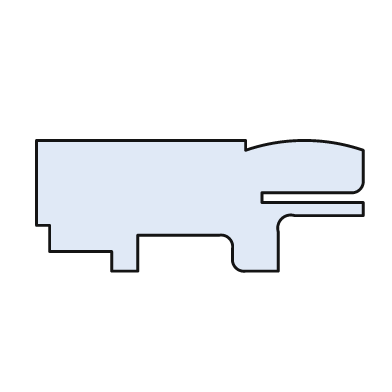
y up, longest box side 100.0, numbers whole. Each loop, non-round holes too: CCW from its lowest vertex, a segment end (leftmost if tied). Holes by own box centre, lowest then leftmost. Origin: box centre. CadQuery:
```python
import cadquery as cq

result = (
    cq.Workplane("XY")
    .moveTo(-27.0, -20.0)
    .lineTo(-19.0, -20.0)
    .lineTo(-19.0, -9.0)
    .lineTo(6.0, -9.0)
    .threePointArc((9.0, -10.0), (10.0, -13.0))
    .lineTo(10.0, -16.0)
    .threePointArc((11.0, -19.0), (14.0, -20.0))
    .lineTo(24.0, -20.0)
    .lineTo(24.0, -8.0)
    .threePointArc((25.0, -4.0), (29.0, -3.0))
    .lineTo(50.0, -3.0)
    .lineTo(50.0, 1.0)
    .lineTo(19.0, 1.0)
    .lineTo(19.0, 4.0)
    .lineTo(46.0, 4.0)
    .threePointArc((49.0, 5.0), (50.0, 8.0))
    .lineTo(50.0, 17.0)
    .threePointArc((32.0, 20.0), (14.0, 17.0))
    .lineTo(14.0, 20.0)
    .lineTo(-50.0, 20.0)
    .lineTo(-50.0, -6.0)
    .lineTo(-46.0, -6.0)
    .lineTo(-46.0, -14.0)
    .lineTo(-27.0, -14.0)
    .close()
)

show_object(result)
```